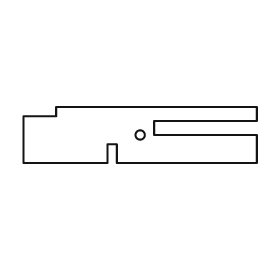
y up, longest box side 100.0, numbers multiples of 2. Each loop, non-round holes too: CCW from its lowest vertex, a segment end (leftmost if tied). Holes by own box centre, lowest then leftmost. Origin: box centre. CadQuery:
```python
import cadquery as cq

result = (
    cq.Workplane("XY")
    .moveTo(-50.0, -12.0)
    .lineTo(-14.0, -12.0)
    .lineTo(-14.0, -4.0)
    .lineTo(-10.0, -4.0)
    .lineTo(-10.0, -12.0)
    .lineTo(50.0, -12.0)
    .lineTo(50.0, 0.0)
    .lineTo(6.0, 0.0)
    .lineTo(6.0, 6.0)
    .lineTo(50.0, 6.0)
    .lineTo(50.0, 12.0)
    .lineTo(-36.0, 12.0)
    .lineTo(-36.0, 8.0)
    .lineTo(-50.0, 8.0)
    .close()
    .moveTo(0.0, 0.0)
    .circle(2.0)
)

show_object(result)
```